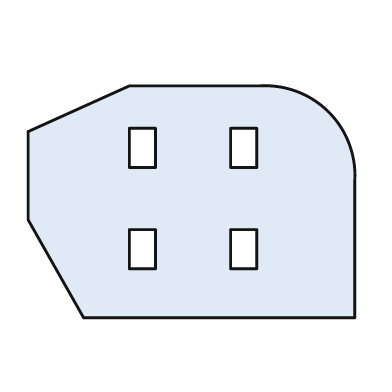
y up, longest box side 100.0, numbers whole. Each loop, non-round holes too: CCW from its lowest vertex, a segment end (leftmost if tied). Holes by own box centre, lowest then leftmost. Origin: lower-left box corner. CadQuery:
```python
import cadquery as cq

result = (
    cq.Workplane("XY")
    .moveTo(17.0, 0.0)
    .lineTo(100.0, 0.0)
    .lineTo(100.0, 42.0)
    .threePointArc((92.0, 63.0), (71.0, 71.0))
    .lineTo(31.0, 71.0)
    .lineTo(0.0, 57.0)
    .lineTo(0.0, 30.0)
    .close()
    .moveTo(31.0, 15.0)
    .lineTo(39.0, 15.0)
    .lineTo(39.0, 27.0)
    .lineTo(31.0, 27.0)
    .close()
    .moveTo(62.0, 15.0)
    .lineTo(70.0, 15.0)
    .lineTo(70.0, 27.0)
    .lineTo(62.0, 27.0)
    .close()
    .moveTo(31.0, 46.0)
    .lineTo(39.0, 46.0)
    .lineTo(39.0, 58.0)
    .lineTo(31.0, 58.0)
    .close()
    .moveTo(62.0, 46.0)
    .lineTo(70.0, 46.0)
    .lineTo(70.0, 58.0)
    .lineTo(62.0, 58.0)
    .close()
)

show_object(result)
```